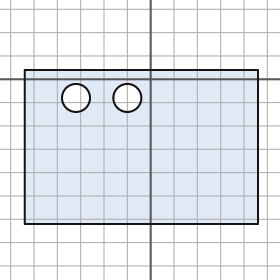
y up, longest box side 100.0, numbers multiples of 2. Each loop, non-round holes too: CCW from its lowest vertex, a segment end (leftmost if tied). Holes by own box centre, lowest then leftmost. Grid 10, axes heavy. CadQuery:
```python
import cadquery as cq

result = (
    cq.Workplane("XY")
    .moveTo(-54.0, -62.0)
    .lineTo(46.0, -62.0)
    .lineTo(46.0, 4.0)
    .lineTo(-54.0, 4.0)
    .close()
    .moveTo(-32.0, -8.0)
    .circle(6.0)
    .moveTo(-10.0, -8.0)
    .circle(6.0)
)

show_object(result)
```